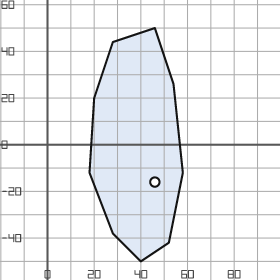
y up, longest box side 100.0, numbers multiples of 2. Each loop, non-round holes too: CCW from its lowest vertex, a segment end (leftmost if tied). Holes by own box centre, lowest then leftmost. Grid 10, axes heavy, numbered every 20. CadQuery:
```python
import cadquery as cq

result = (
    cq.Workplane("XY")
    .moveTo(40.0, -50.0)
    .lineTo(52.0, -42.0)
    .lineTo(58.0, -12.0)
    .lineTo(54.0, 26.0)
    .lineTo(46.0, 50.0)
    .lineTo(28.0, 44.0)
    .lineTo(20.0, 20.0)
    .lineTo(18.0, -12.0)
    .lineTo(28.0, -38.0)
    .close()
    .moveTo(46.0, -16.0)
    .circle(2.0)
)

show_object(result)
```